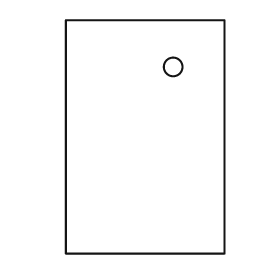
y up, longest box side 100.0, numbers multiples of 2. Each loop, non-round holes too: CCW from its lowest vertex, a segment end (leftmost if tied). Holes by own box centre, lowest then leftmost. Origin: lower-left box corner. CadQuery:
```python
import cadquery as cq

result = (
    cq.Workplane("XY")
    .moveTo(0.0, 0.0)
    .lineTo(68.0, 0.0)
    .lineTo(68.0, 100.0)
    .lineTo(0.0, 100.0)
    .close()
    .moveTo(46.0, 80.0)
    .circle(4.0)
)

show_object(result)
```